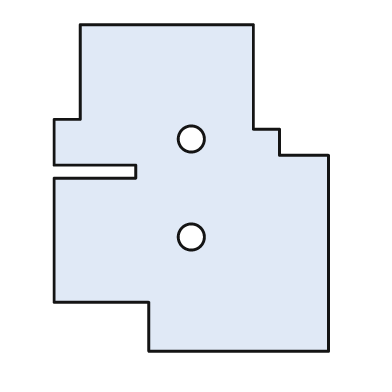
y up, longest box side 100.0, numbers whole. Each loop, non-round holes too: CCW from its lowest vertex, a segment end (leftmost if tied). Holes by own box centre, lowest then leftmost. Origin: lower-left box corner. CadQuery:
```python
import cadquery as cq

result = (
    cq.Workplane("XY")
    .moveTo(29.0, 0.0)
    .lineTo(84.0, 0.0)
    .lineTo(84.0, 60.0)
    .lineTo(69.0, 60.0)
    .lineTo(69.0, 68.0)
    .lineTo(61.0, 68.0)
    .lineTo(61.0, 100.0)
    .lineTo(8.0, 100.0)
    .lineTo(8.0, 71.0)
    .lineTo(0.0, 71.0)
    .lineTo(0.0, 57.0)
    .lineTo(25.0, 57.0)
    .lineTo(25.0, 53.0)
    .lineTo(0.0, 53.0)
    .lineTo(0.0, 15.0)
    .lineTo(29.0, 15.0)
    .close()
    .moveTo(42.0, 35.0)
    .circle(4.0)
    .moveTo(42.0, 65.0)
    .circle(4.0)
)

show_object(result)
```